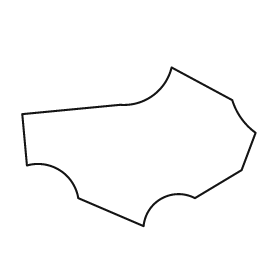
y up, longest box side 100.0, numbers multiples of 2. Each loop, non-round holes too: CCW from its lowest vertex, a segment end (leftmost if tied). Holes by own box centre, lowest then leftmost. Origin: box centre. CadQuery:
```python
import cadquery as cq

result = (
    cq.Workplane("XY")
    .moveTo(2.0, -34.0)
    .threePointArc((10.0, -22.0), (24.0, -22.0))
    .lineTo(44.0, -10.0)
    .lineTo(50.0, 6.0)
    .threePointArc((44.0, 12.0), (40.0, 20.0))
    .lineTo(14.0, 34.0)
    .threePointArc((6.0, 22.0), (-8.0, 18.0))
    .lineTo(-50.0, 14.0)
    .lineTo(-48.0, -8.0)
    .threePointArc((-34.0, -10.0), (-26.0, -22.0))
    .close()
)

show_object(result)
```